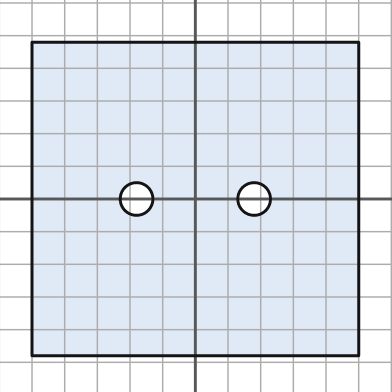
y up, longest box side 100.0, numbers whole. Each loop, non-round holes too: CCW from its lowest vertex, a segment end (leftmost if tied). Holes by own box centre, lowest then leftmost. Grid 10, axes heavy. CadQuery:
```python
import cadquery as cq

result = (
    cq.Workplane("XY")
    .moveTo(-50.0, -48.0)
    .lineTo(50.0, -48.0)
    .lineTo(50.0, 48.0)
    .lineTo(-50.0, 48.0)
    .close()
    .moveTo(-18.0, 0.0)
    .circle(5.0)
    .moveTo(18.0, 0.0)
    .circle(5.0)
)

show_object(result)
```